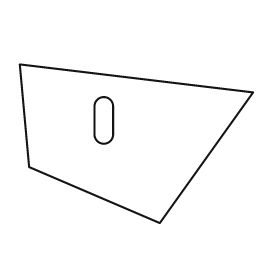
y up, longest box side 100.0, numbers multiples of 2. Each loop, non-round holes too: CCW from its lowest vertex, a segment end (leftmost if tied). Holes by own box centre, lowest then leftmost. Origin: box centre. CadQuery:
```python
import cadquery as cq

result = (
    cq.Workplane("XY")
    .moveTo(10.0, -34.0)
    .lineTo(50.0, 22.0)
    .lineTo(-50.0, 34.0)
    .lineTo(-46.0, -10.0)
    .close()
    .moveTo(-18.0, 4.0)
    .threePointArc((-14.0, 0.0), (-10.0, 4.0))
    .lineTo(-10.0, 16.0)
    .threePointArc((-14.0, 20.0), (-18.0, 16.0))
    .close()
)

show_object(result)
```